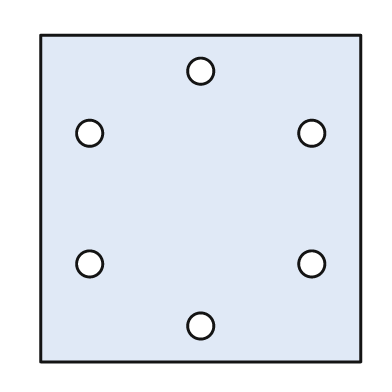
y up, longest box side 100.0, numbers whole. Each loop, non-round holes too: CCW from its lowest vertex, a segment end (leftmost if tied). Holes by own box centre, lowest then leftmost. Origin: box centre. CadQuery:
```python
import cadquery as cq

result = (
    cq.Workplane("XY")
    .moveTo(-49.0, -50.0)
    .lineTo(49.0, -50.0)
    .lineTo(49.0, 50.0)
    .lineTo(-49.0, 50.0)
    .close()
    .moveTo(0.0, -39.0)
    .circle(4.0)
    .moveTo(-34.0, -20.0)
    .circle(4.0)
    .moveTo(34.0, -20.0)
    .circle(4.0)
    .moveTo(-34.0, 20.0)
    .circle(4.0)
    .moveTo(34.0, 20.0)
    .circle(4.0)
    .moveTo(0.0, 39.0)
    .circle(4.0)
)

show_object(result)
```